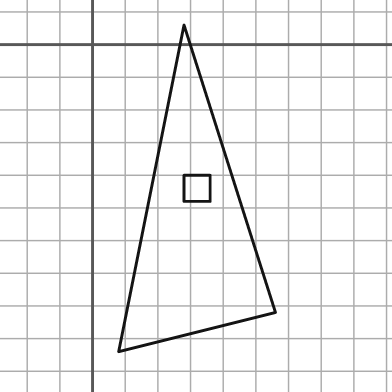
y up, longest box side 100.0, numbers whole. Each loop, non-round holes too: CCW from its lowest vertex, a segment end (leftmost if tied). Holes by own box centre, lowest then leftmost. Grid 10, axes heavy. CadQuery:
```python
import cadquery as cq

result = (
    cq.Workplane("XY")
    .moveTo(8.0, -94.0)
    .lineTo(56.0, -82.0)
    .lineTo(28.0, 6.0)
    .close()
    .moveTo(28.0, -48.0)
    .lineTo(36.0, -48.0)
    .lineTo(36.0, -40.0)
    .lineTo(28.0, -40.0)
    .close()
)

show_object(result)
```